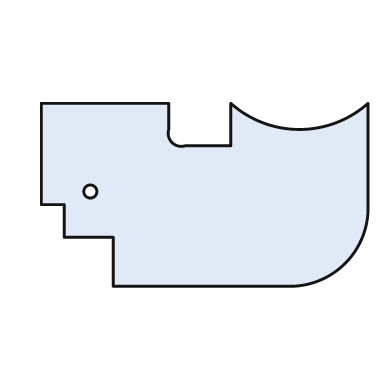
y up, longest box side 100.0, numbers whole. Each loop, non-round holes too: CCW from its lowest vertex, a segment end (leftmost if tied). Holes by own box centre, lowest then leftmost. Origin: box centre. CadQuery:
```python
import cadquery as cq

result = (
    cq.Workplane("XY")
    .moveTo(-28.0, -28.0)
    .lineTo(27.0, -28.0)
    .threePointArc((43.0, -21.0), (50.0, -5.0))
    .lineTo(50.0, 28.0)
    .threePointArc((29.0, 20.0), (8.0, 28.0))
    .lineTo(8.0, 15.0)
    .lineTo(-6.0, 15.0)
    .threePointArc((-10.0, 16.0), (-11.0, 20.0))
    .lineTo(-11.0, 28.0)
    .lineTo(-50.0, 28.0)
    .lineTo(-50.0, -3.0)
    .lineTo(-43.0, -3.0)
    .lineTo(-43.0, -13.0)
    .lineTo(-28.0, -13.0)
    .close()
    .moveTo(-35.0, 1.0)
    .circle(2.0)
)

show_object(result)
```